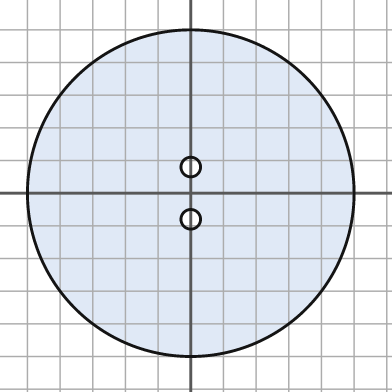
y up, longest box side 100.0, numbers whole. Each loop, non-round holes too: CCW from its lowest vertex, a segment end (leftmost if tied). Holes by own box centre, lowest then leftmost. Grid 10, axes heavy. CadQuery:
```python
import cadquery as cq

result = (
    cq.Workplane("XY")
    .moveTo(0.0, 0.0)
    .circle(50.0)
    .moveTo(0.0, -8.0)
    .circle(3.0)
    .moveTo(0.0, 8.0)
    .circle(3.0)
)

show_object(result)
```